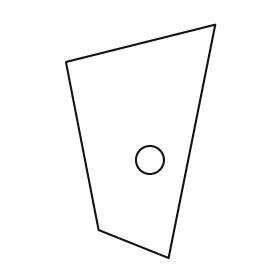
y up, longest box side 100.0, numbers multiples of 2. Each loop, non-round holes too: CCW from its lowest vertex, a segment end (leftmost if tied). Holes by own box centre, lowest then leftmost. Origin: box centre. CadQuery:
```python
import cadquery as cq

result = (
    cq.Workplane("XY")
    .moveTo(12.0, -50.0)
    .lineTo(32.0, 50.0)
    .lineTo(-32.0, 34.0)
    .lineTo(-18.0, -38.0)
    .close()
    .moveTo(4.0, -8.0)
    .circle(6.0)
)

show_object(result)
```